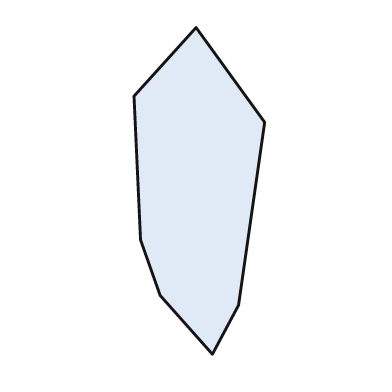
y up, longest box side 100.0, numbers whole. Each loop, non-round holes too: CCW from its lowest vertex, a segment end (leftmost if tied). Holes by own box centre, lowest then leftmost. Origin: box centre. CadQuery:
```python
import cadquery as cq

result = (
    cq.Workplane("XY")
    .moveTo(4.0, -50.0)
    .lineTo(12.0, -35.0)
    .lineTo(20.0, 21.0)
    .lineTo(-1.0, 50.0)
    .lineTo(-20.0, 29.0)
    .lineTo(-18.0, -15.0)
    .lineTo(-12.0, -32.0)
    .close()
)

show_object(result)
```